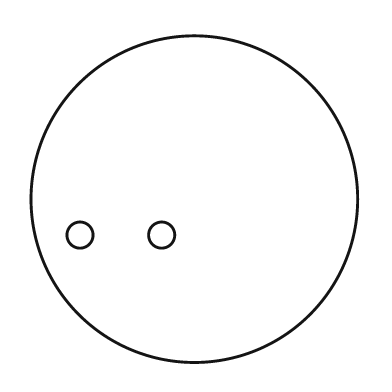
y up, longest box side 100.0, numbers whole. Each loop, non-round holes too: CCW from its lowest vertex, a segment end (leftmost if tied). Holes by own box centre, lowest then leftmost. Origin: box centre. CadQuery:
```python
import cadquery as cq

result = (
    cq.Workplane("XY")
    .moveTo(0.0, 0.0)
    .circle(50.0)
    .moveTo(-35.0, -11.0)
    .circle(4.0)
    .moveTo(-10.0, -11.0)
    .circle(4.0)
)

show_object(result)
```